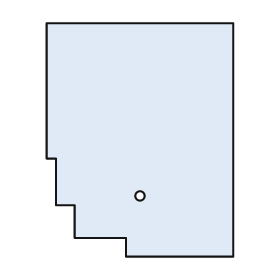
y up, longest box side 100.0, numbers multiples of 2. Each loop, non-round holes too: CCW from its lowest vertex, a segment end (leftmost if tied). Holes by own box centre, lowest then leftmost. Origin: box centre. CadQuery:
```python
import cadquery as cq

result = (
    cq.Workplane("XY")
    .moveTo(-6.0, -50.0)
    .lineTo(40.0, -50.0)
    .lineTo(40.0, 50.0)
    .lineTo(-40.0, 50.0)
    .lineTo(-40.0, -8.0)
    .lineTo(-36.0, -8.0)
    .lineTo(-36.0, -28.0)
    .lineTo(-28.0, -28.0)
    .lineTo(-28.0, -42.0)
    .lineTo(-6.0, -42.0)
    .close()
    .moveTo(0.0, -24.0)
    .circle(2.0)
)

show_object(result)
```